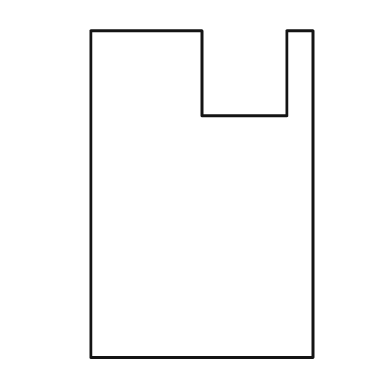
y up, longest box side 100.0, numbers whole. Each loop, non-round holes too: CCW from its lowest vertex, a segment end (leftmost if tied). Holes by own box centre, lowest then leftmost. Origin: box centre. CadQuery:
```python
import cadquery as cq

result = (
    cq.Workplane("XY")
    .moveTo(-34.0, -50.0)
    .lineTo(34.0, -50.0)
    .lineTo(34.0, 50.0)
    .lineTo(26.0, 50.0)
    .lineTo(26.0, 24.0)
    .lineTo(0.0, 24.0)
    .lineTo(0.0, 50.0)
    .lineTo(-34.0, 50.0)
    .close()
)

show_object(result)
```